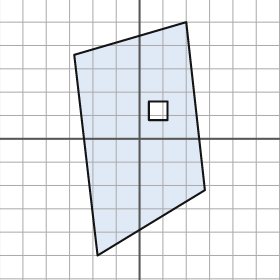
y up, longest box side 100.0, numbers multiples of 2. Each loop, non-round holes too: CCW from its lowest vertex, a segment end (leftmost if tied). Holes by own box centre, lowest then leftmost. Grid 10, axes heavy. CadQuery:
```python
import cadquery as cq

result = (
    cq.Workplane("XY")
    .moveTo(-18.0, -50.0)
    .lineTo(28.0, -22.0)
    .lineTo(20.0, 50.0)
    .lineTo(-28.0, 36.0)
    .close()
    .moveTo(4.0, 8.0)
    .lineTo(12.0, 8.0)
    .lineTo(12.0, 16.0)
    .lineTo(4.0, 16.0)
    .close()
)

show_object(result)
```